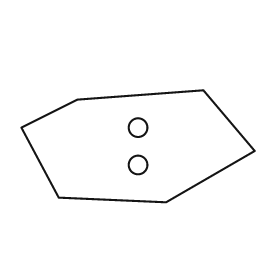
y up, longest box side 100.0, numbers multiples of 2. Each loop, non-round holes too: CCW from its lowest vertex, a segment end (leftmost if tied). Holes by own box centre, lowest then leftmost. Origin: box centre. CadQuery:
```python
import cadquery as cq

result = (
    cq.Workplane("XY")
    .moveTo(12.0, -24.0)
    .lineTo(50.0, -2.0)
    .lineTo(28.0, 24.0)
    .lineTo(-26.0, 20.0)
    .lineTo(-50.0, 8.0)
    .lineTo(-34.0, -22.0)
    .close()
    .moveTo(0.0, -8.0)
    .circle(4.0)
    .moveTo(0.0, 8.0)
    .circle(4.0)
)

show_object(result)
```